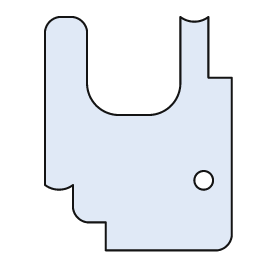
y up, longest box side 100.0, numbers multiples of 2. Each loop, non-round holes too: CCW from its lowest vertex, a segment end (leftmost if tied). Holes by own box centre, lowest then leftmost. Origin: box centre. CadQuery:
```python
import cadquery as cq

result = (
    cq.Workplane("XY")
    .moveTo(-14.0, -50.0)
    .lineTo(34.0, -50.0)
    .threePointArc((38.0, -48.0), (40.0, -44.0))
    .lineTo(40.0, 24.0)
    .lineTo(30.0, 24.0)
    .lineTo(30.0, 50.0)
    .threePointArc((24.0, 48.0), (18.0, 50.0))
    .lineTo(18.0, 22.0)
    .threePointArc((14.0, 12.0), (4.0, 8.0))
    .lineTo(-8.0, 8.0)
    .threePointArc((-18.0, 12.0), (-22.0, 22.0))
    .lineTo(-22.0, 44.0)
    .threePointArc((-24.0, 48.0), (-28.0, 50.0))
    .lineTo(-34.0, 50.0)
    .threePointArc((-38.0, 48.0), (-40.0, 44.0))
    .lineTo(-40.0, -22.0)
    .threePointArc((-34.0, -24.0), (-28.0, -22.0))
    .lineTo(-28.0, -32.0)
    .threePointArc((-26.0, -36.0), (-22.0, -38.0))
    .lineTo(-14.0, -38.0)
    .close()
    .moveTo(28.0, -20.0)
    .circle(4.0)
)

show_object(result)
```